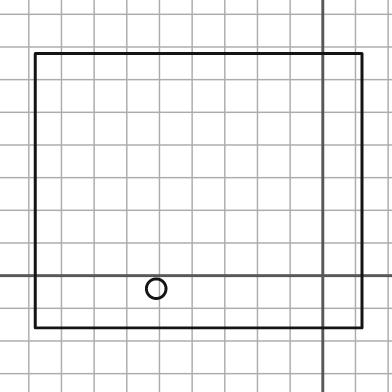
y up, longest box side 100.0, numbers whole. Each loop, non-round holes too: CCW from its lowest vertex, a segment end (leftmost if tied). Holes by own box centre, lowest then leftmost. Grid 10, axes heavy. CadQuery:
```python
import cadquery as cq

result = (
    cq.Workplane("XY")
    .moveTo(-88.0, -16.0)
    .lineTo(12.0, -16.0)
    .lineTo(12.0, 68.0)
    .lineTo(-88.0, 68.0)
    .close()
    .moveTo(-51.0, -4.0)
    .circle(3.0)
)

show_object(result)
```